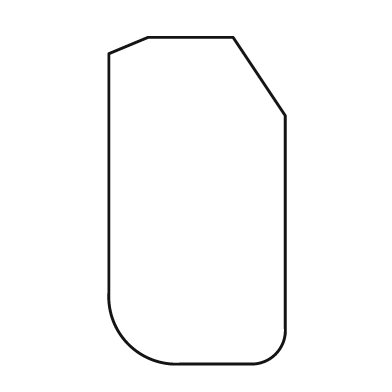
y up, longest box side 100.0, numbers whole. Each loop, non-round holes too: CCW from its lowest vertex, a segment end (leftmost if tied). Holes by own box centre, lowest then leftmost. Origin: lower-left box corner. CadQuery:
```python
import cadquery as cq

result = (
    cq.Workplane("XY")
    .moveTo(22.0, 0.0)
    .lineTo(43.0, 0.0)
    .threePointArc((51.0, 3.0), (54.0, 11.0))
    .lineTo(54.0, 76.0)
    .lineTo(38.0, 100.0)
    .lineTo(12.0, 100.0)
    .lineTo(0.0, 95.0)
    .lineTo(0.0, 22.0)
    .threePointArc((6.0, 6.0), (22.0, 0.0))
    .close()
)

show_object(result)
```